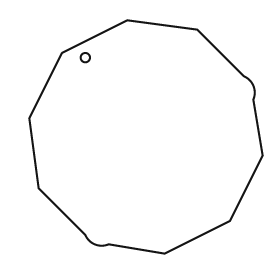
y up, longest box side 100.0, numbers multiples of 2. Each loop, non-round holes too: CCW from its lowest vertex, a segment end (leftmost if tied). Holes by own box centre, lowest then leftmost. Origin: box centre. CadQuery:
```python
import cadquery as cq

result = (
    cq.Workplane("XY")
    .moveTo(8.0, -50.0)
    .lineTo(36.0, -36.0)
    .lineTo(50.0, -8.0)
    .lineTo(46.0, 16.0)
    .threePointArc((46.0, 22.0), (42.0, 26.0))
    .lineTo(22.0, 46.0)
    .lineTo(-8.0, 50.0)
    .lineTo(-36.0, 36.0)
    .lineTo(-50.0, 8.0)
    .lineTo(-46.0, -22.0)
    .lineTo(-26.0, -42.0)
    .threePointArc((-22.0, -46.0), (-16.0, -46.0))
    .close()
    .moveTo(-26.0, 34.0)
    .circle(2.0)
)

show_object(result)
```